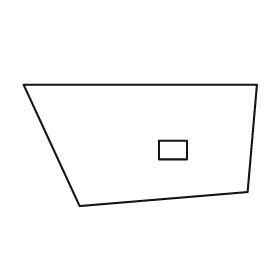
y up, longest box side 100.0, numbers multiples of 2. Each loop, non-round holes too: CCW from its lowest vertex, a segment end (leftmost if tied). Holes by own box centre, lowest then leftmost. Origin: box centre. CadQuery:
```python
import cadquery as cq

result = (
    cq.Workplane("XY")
    .moveTo(-26.0, -26.0)
    .lineTo(46.0, -20.0)
    .lineTo(50.0, 26.0)
    .lineTo(-50.0, 26.0)
    .close()
    .moveTo(8.0, -6.0)
    .lineTo(20.0, -6.0)
    .lineTo(20.0, 2.0)
    .lineTo(8.0, 2.0)
    .close()
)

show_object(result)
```